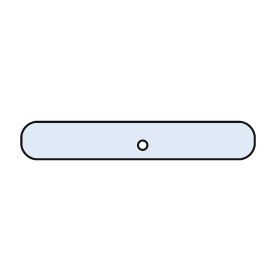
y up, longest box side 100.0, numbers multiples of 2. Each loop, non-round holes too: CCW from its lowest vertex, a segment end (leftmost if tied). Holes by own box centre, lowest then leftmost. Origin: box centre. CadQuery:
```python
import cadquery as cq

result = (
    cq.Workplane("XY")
    .moveTo(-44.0, -8.0)
    .lineTo(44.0, -8.0)
    .threePointArc((48.0, -6.0), (50.0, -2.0))
    .lineTo(50.0, 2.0)
    .threePointArc((48.0, 6.0), (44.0, 8.0))
    .lineTo(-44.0, 8.0)
    .threePointArc((-48.0, 6.0), (-50.0, 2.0))
    .lineTo(-50.0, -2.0)
    .threePointArc((-48.0, -6.0), (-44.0, -8.0))
    .close()
    .moveTo(2.0, -2.0)
    .circle(2.0)
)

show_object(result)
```